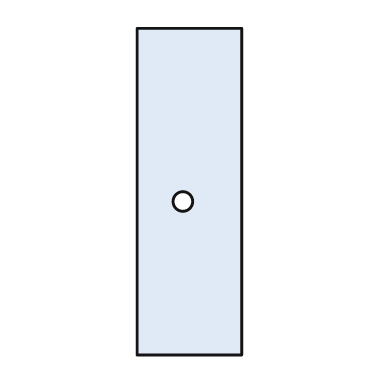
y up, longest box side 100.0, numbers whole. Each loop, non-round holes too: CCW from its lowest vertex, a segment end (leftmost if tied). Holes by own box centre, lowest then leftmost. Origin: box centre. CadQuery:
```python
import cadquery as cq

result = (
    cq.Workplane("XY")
    .moveTo(-16.0, -50.0)
    .lineTo(16.0, -50.0)
    .lineTo(16.0, 50.0)
    .lineTo(-16.0, 50.0)
    .close()
    .moveTo(-2.0, -3.0)
    .circle(3.0)
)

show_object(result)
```